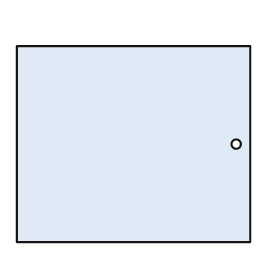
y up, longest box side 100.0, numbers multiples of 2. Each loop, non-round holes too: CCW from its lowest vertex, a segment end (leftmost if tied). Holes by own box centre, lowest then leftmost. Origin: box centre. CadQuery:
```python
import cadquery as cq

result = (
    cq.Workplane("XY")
    .moveTo(-50.0, -42.0)
    .lineTo(50.0, -42.0)
    .lineTo(50.0, 42.0)
    .lineTo(-50.0, 42.0)
    .close()
    .moveTo(44.0, 0.0)
    .circle(2.0)
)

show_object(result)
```